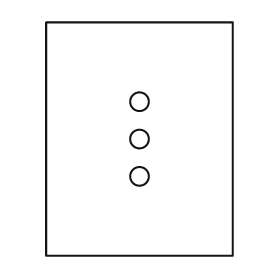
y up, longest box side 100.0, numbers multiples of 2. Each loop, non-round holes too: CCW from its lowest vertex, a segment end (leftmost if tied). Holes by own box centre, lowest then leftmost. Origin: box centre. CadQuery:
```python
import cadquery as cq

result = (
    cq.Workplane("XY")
    .moveTo(-40.0, -50.0)
    .lineTo(40.0, -50.0)
    .lineTo(40.0, 50.0)
    .lineTo(-40.0, 50.0)
    .close()
    .moveTo(0.0, -16.0)
    .circle(4.0)
    .moveTo(0.0, 0.0)
    .circle(4.0)
    .moveTo(0.0, 16.0)
    .circle(4.0)
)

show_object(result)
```